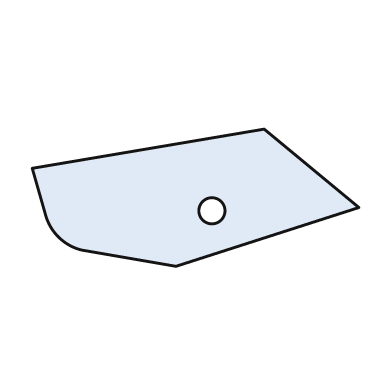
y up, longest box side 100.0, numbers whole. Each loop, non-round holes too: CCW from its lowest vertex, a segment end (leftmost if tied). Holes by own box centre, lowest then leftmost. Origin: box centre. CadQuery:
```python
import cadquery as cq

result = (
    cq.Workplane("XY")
    .moveTo(-6.0, -21.0)
    .lineTo(50.0, -3.0)
    .lineTo(21.0, 21.0)
    .lineTo(-50.0, 9.0)
    .lineTo(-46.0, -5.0)
    .threePointArc((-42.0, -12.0), (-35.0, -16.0))
    .close()
    .moveTo(5.0, -4.0)
    .circle(4.0)
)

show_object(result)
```